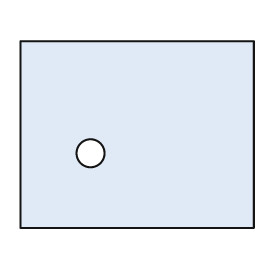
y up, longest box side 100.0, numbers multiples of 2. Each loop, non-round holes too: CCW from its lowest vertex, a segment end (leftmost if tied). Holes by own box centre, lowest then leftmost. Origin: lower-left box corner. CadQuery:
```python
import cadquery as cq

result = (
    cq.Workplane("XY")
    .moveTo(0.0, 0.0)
    .lineTo(100.0, 0.0)
    .lineTo(100.0, 80.0)
    .lineTo(0.0, 80.0)
    .close()
    .moveTo(30.0, 32.0)
    .circle(6.0)
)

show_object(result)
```